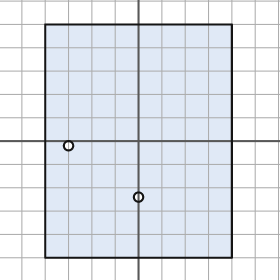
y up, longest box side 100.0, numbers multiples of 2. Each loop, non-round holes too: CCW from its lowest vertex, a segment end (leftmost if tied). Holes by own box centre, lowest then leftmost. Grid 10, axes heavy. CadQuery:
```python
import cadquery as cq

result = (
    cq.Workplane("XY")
    .moveTo(-40.0, -50.0)
    .lineTo(40.0, -50.0)
    .lineTo(40.0, 50.0)
    .lineTo(-40.0, 50.0)
    .close()
    .moveTo(0.0, -24.0)
    .circle(2.0)
    .moveTo(-30.0, -2.0)
    .circle(2.0)
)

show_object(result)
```